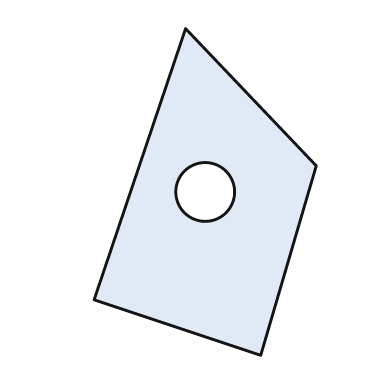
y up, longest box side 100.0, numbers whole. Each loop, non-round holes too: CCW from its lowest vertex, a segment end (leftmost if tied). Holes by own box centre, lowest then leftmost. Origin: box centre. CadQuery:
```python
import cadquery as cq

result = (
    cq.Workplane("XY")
    .moveTo(17.0, -50.0)
    .lineTo(34.0, 8.0)
    .lineTo(-6.0, 50.0)
    .lineTo(-34.0, -33.0)
    .close()
    .moveTo(0.0, 0.0)
    .circle(9.0)
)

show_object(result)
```